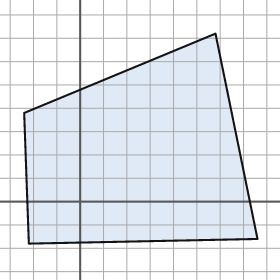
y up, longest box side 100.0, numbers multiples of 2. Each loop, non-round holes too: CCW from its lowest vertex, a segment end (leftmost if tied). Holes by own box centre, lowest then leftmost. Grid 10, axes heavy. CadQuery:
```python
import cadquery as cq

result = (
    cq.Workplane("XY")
    .moveTo(-22.0, -18.0)
    .lineTo(76.0, -16.0)
    .lineTo(58.0, 72.0)
    .lineTo(-24.0, 38.0)
    .close()
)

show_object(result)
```